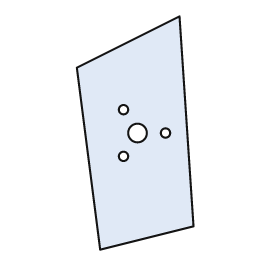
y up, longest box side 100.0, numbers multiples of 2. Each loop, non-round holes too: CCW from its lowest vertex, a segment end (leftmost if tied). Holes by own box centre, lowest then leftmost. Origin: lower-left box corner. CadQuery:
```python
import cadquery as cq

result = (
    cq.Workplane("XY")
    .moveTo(10.0, 0.0)
    .lineTo(50.0, 10.0)
    .lineTo(44.0, 100.0)
    .lineTo(0.0, 78.0)
    .close()
    .moveTo(20.0, 40.0)
    .circle(2.0)
    .moveTo(26.0, 50.0)
    .circle(4.0)
    .moveTo(38.0, 50.0)
    .circle(2.0)
    .moveTo(20.0, 60.0)
    .circle(2.0)
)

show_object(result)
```